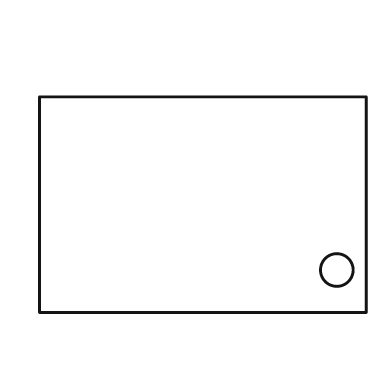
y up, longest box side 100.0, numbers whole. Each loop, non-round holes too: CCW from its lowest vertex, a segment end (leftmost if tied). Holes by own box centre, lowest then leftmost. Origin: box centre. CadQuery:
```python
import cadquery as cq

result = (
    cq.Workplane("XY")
    .moveTo(-50.0, -33.0)
    .lineTo(50.0, -33.0)
    .lineTo(50.0, 33.0)
    .lineTo(-50.0, 33.0)
    .close()
    .moveTo(41.0, -20.0)
    .circle(5.0)
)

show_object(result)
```